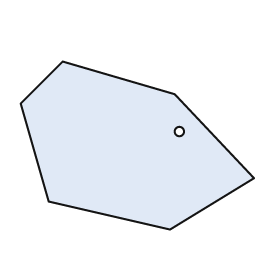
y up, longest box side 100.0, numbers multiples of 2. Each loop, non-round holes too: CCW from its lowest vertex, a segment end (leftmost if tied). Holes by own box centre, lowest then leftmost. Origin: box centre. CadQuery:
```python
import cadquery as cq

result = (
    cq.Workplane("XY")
    .moveTo(14.0, -36.0)
    .lineTo(50.0, -14.0)
    .lineTo(16.0, 22.0)
    .lineTo(-32.0, 36.0)
    .lineTo(-50.0, 18.0)
    .lineTo(-38.0, -24.0)
    .close()
    .moveTo(18.0, 6.0)
    .circle(2.0)
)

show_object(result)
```